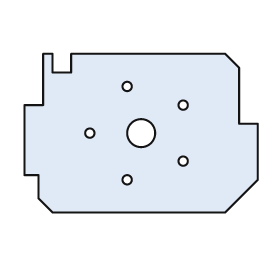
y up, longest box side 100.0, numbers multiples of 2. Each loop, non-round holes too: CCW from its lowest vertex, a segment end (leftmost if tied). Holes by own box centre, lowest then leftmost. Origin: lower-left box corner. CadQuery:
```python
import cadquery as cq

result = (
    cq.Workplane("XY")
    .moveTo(12.0, 0.0)
    .lineTo(86.0, 0.0)
    .lineTo(100.0, 14.0)
    .lineTo(100.0, 38.0)
    .lineTo(92.0, 38.0)
    .lineTo(92.0, 62.0)
    .lineTo(86.0, 68.0)
    .lineTo(20.0, 68.0)
    .lineTo(20.0, 60.0)
    .lineTo(12.0, 60.0)
    .lineTo(12.0, 68.0)
    .lineTo(8.0, 68.0)
    .lineTo(8.0, 46.0)
    .lineTo(0.0, 46.0)
    .lineTo(0.0, 16.0)
    .lineTo(6.0, 16.0)
    .lineTo(6.0, 6.0)
    .close()
    .moveTo(44.0, 14.0)
    .circle(2.0)
    .moveTo(68.0, 22.0)
    .circle(2.0)
    .moveTo(28.0, 34.0)
    .circle(2.0)
    .moveTo(50.0, 34.0)
    .circle(6.0)
    .moveTo(68.0, 46.0)
    .circle(2.0)
    .moveTo(44.0, 54.0)
    .circle(2.0)
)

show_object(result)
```